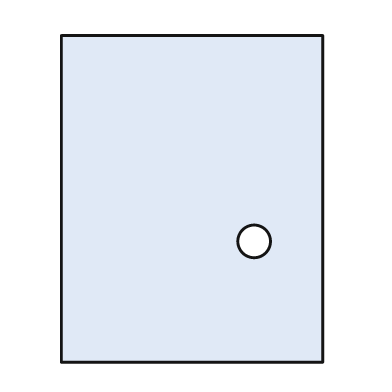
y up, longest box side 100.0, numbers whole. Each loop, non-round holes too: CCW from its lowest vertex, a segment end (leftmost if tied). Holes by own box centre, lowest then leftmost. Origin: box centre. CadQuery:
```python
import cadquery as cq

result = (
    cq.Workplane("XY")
    .moveTo(-40.0, -50.0)
    .lineTo(40.0, -50.0)
    .lineTo(40.0, 50.0)
    .lineTo(-40.0, 50.0)
    .close()
    .moveTo(19.0, -13.0)
    .circle(5.0)
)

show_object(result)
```